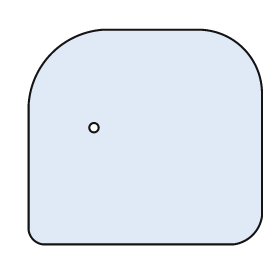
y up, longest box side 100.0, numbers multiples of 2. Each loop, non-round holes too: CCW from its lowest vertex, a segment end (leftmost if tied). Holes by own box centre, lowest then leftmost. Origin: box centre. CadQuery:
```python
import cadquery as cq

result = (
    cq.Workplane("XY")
    .moveTo(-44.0, -46.0)
    .lineTo(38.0, -46.0)
    .threePointArc((46.0, -42.0), (50.0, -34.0))
    .lineTo(50.0, 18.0)
    .threePointArc((42.0, 38.0), (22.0, 46.0))
    .lineTo(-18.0, 46.0)
    .threePointArc((-40.0, 36.0), (-50.0, 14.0))
    .lineTo(-50.0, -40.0)
    .threePointArc((-48.0, -44.0), (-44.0, -46.0))
    .close()
    .moveTo(-22.0, 4.0)
    .circle(2.0)
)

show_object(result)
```